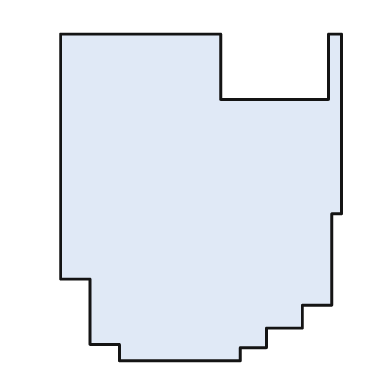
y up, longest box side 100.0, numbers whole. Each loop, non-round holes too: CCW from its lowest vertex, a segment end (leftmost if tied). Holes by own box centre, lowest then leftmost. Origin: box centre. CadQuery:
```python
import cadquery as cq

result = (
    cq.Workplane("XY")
    .moveTo(-25.0, -50.0)
    .lineTo(12.0, -50.0)
    .lineTo(12.0, -46.0)
    .lineTo(20.0, -46.0)
    .lineTo(20.0, -40.0)
    .lineTo(31.0, -40.0)
    .lineTo(31.0, -33.0)
    .lineTo(40.0, -33.0)
    .lineTo(40.0, -5.0)
    .lineTo(43.0, -5.0)
    .lineTo(43.0, 50.0)
    .lineTo(39.0, 50.0)
    .lineTo(39.0, 30.0)
    .lineTo(6.0, 30.0)
    .lineTo(6.0, 50.0)
    .lineTo(-43.0, 50.0)
    .lineTo(-43.0, -25.0)
    .lineTo(-34.0, -25.0)
    .lineTo(-34.0, -45.0)
    .lineTo(-25.0, -45.0)
    .close()
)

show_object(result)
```